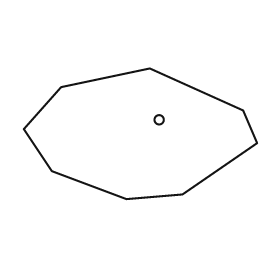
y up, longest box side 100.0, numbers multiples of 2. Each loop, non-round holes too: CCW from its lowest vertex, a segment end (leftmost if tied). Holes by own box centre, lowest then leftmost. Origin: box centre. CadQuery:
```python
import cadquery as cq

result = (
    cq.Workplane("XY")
    .moveTo(-6.0, -28.0)
    .lineTo(18.0, -26.0)
    .lineTo(50.0, -4.0)
    .lineTo(44.0, 10.0)
    .lineTo(4.0, 28.0)
    .lineTo(-34.0, 20.0)
    .lineTo(-50.0, 2.0)
    .lineTo(-38.0, -16.0)
    .close()
    .moveTo(8.0, 6.0)
    .circle(2.0)
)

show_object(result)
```